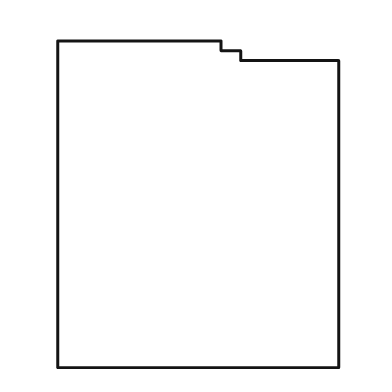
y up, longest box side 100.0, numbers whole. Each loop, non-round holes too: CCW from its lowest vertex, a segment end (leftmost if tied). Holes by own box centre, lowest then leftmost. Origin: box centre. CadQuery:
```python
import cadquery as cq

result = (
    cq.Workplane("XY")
    .moveTo(-43.0, -50.0)
    .lineTo(43.0, -50.0)
    .lineTo(43.0, 44.0)
    .lineTo(13.0, 44.0)
    .lineTo(13.0, 47.0)
    .lineTo(7.0, 47.0)
    .lineTo(7.0, 50.0)
    .lineTo(-43.0, 50.0)
    .close()
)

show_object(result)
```